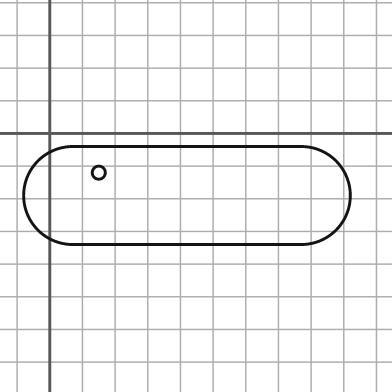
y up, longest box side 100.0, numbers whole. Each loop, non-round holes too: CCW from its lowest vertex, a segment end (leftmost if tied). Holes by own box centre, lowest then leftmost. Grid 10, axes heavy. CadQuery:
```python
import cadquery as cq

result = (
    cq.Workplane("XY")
    .moveTo(7.0, -34.0)
    .lineTo(77.0, -34.0)
    .threePointArc((92.0, -19.0), (77.0, -4.0))
    .lineTo(7.0, -4.0)
    .threePointArc((-8.0, -19.0), (7.0, -34.0))
    .close()
    .moveTo(15.0, -12.0)
    .circle(2.0)
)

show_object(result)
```